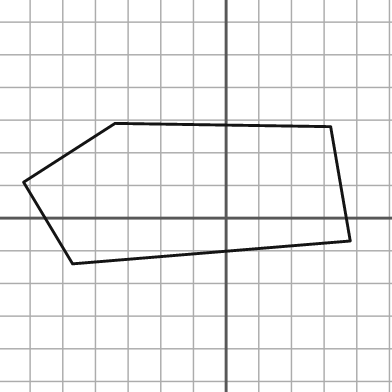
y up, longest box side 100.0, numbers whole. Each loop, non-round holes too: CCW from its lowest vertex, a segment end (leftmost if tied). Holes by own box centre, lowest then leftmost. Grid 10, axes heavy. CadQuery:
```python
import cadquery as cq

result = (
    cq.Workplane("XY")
    .moveTo(-47.0, -14.0)
    .lineTo(38.0, -7.0)
    .lineTo(32.0, 28.0)
    .lineTo(-34.0, 29.0)
    .lineTo(-62.0, 11.0)
    .close()
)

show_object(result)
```